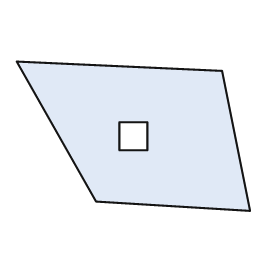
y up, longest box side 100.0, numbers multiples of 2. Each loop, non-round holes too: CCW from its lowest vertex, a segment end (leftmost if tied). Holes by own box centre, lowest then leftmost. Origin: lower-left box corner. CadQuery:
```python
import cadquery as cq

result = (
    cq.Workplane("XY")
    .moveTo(100.0, 0.0)
    .lineTo(88.0, 60.0)
    .lineTo(0.0, 64.0)
    .lineTo(34.0, 4.0)
    .close()
    .moveTo(44.0, 26.0)
    .lineTo(56.0, 26.0)
    .lineTo(56.0, 38.0)
    .lineTo(44.0, 38.0)
    .close()
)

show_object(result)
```